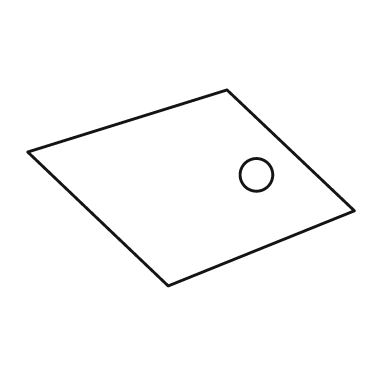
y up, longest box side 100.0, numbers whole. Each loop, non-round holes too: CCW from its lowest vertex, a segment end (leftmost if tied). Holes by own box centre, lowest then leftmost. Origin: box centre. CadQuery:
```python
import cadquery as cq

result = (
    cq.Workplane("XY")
    .moveTo(-7.0, -30.0)
    .lineTo(50.0, -7.0)
    .lineTo(11.0, 30.0)
    .lineTo(-50.0, 11.0)
    .close()
    .moveTo(20.0, 4.0)
    .circle(5.0)
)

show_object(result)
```